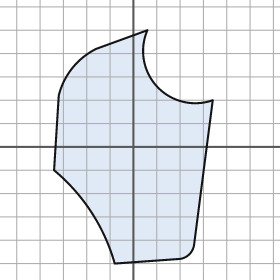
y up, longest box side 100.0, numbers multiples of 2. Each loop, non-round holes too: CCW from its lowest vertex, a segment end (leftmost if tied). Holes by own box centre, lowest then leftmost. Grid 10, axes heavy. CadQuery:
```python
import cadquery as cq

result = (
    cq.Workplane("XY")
    .moveTo(-8.0, -50.0)
    .lineTo(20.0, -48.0)
    .threePointArc((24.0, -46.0), (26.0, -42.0))
    .lineTo(34.0, 20.0)
    .threePointArc((10.0, 26.0), (6.0, 50.0))
    .lineTo(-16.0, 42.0)
    .threePointArc((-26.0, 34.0), (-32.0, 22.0))
    .lineTo(-34.0, -10.0)
    .threePointArc((-18.0, -28.0), (-8.0, -50.0))
    .close()
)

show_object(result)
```